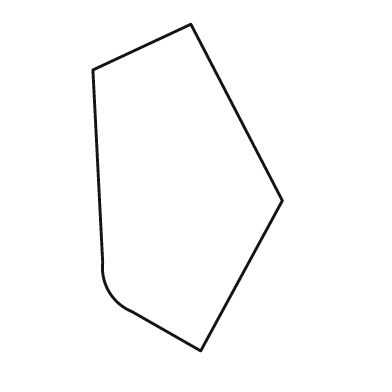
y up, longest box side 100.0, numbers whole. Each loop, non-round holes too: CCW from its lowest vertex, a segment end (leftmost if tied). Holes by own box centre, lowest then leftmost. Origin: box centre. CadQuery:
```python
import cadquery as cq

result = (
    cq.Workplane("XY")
    .moveTo(4.0, -50.0)
    .lineTo(29.0, -4.0)
    .lineTo(1.0, 50.0)
    .lineTo(-29.0, 36.0)
    .lineTo(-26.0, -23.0)
    .threePointArc((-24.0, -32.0), (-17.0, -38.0))
    .close()
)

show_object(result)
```